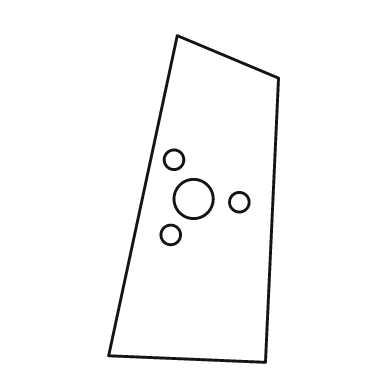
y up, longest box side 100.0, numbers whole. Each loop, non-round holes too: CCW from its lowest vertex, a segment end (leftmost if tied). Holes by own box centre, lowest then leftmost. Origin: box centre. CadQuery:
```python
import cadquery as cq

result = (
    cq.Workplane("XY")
    .moveTo(22.0, -50.0)
    .lineTo(26.0, 37.0)
    .lineTo(-5.0, 50.0)
    .lineTo(-26.0, -48.0)
    .close()
    .moveTo(-7.0, -11.0)
    .circle(3.0)
    .moveTo(14.0, -1.0)
    .circle(3.0)
    .moveTo(0.0, 0.0)
    .circle(6.0)
    .moveTo(-6.0, 12.0)
    .circle(3.0)
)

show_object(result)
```